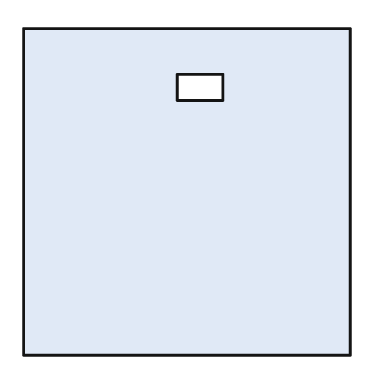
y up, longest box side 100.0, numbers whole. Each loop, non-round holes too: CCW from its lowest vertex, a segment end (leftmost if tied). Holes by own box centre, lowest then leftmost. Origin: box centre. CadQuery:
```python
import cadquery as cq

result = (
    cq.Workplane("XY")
    .moveTo(-50.0, -50.0)
    .lineTo(50.0, -50.0)
    .lineTo(50.0, 50.0)
    .lineTo(-50.0, 50.0)
    .close()
    .moveTo(-3.0, 28.0)
    .lineTo(11.0, 28.0)
    .lineTo(11.0, 36.0)
    .lineTo(-3.0, 36.0)
    .close()
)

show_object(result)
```